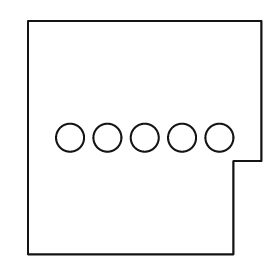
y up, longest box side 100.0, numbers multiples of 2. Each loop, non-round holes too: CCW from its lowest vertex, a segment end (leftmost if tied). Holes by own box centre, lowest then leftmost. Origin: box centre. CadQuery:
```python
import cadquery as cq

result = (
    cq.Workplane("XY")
    .moveTo(-50.0, -50.0)
    .lineTo(38.0, -50.0)
    .lineTo(38.0, -10.0)
    .lineTo(50.0, -10.0)
    .lineTo(50.0, 50.0)
    .lineTo(-50.0, 50.0)
    .close()
    .moveTo(-32.0, 0.0)
    .circle(6.0)
    .moveTo(-16.0, 0.0)
    .circle(6.0)
    .moveTo(0.0, 0.0)
    .circle(6.0)
    .moveTo(16.0, 0.0)
    .circle(6.0)
    .moveTo(32.0, 0.0)
    .circle(6.0)
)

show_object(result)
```